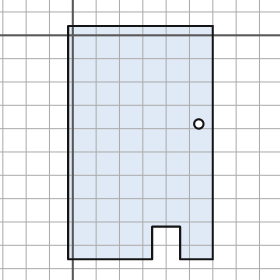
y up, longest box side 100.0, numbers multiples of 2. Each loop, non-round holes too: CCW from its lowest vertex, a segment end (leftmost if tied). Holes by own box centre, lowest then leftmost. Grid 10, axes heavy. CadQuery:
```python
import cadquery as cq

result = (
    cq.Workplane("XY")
    .moveTo(-2.0, -96.0)
    .lineTo(34.0, -96.0)
    .lineTo(34.0, -82.0)
    .lineTo(46.0, -82.0)
    .lineTo(46.0, -96.0)
    .lineTo(60.0, -96.0)
    .lineTo(60.0, 4.0)
    .lineTo(-2.0, 4.0)
    .close()
    .moveTo(54.0, -38.0)
    .circle(2.0)
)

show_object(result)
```